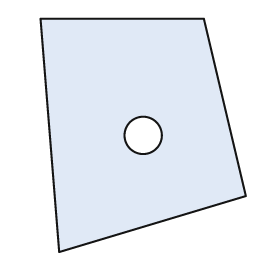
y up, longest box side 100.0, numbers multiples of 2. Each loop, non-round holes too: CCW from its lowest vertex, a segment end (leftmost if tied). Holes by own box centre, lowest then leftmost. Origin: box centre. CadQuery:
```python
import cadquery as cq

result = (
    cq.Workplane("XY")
    .moveTo(-36.0, -50.0)
    .lineTo(44.0, -26.0)
    .lineTo(26.0, 50.0)
    .lineTo(-44.0, 50.0)
    .close()
    .moveTo(0.0, 0.0)
    .circle(8.0)
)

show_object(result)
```